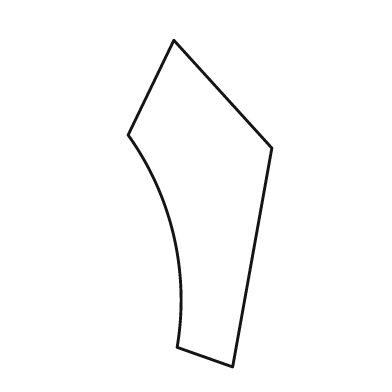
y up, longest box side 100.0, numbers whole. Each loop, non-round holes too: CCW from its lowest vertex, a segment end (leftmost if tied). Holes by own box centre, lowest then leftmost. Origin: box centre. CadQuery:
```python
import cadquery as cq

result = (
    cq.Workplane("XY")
    .moveTo(10.0, -50.0)
    .lineTo(22.0, 17.0)
    .lineTo(-8.0, 50.0)
    .lineTo(-22.0, 21.0)
    .threePointArc((-8.0, -10.0), (-7.0, -44.0))
    .close()
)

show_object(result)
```